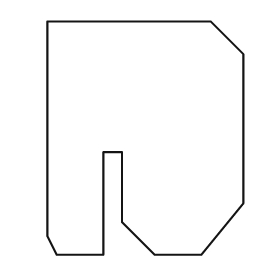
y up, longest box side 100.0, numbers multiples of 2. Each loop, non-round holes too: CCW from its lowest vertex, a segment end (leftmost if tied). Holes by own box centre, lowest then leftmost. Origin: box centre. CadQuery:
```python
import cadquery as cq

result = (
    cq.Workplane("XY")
    .moveTo(-38.0, -50.0)
    .lineTo(-18.0, -50.0)
    .lineTo(-18.0, -6.0)
    .lineTo(-10.0, -6.0)
    .lineTo(-10.0, -36.0)
    .lineTo(4.0, -50.0)
    .lineTo(24.0, -50.0)
    .lineTo(42.0, -28.0)
    .lineTo(42.0, 36.0)
    .lineTo(28.0, 50.0)
    .lineTo(-42.0, 50.0)
    .lineTo(-42.0, -42.0)
    .close()
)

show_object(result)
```